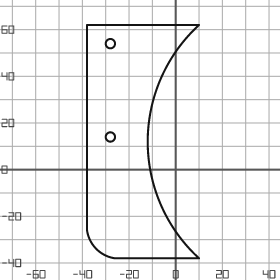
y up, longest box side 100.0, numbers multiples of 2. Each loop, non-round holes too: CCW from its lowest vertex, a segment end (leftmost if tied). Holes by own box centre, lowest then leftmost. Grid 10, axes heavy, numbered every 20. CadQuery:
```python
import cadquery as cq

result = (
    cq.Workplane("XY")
    .moveTo(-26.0, -38.0)
    .lineTo(10.0, -38.0)
    .threePointArc((-12.0, 12.0), (10.0, 62.0))
    .lineTo(-38.0, 62.0)
    .lineTo(-38.0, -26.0)
    .threePointArc((-34.0, -34.0), (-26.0, -38.0))
    .close()
    .moveTo(-28.0, 14.0)
    .circle(2.0)
    .moveTo(-28.0, 54.0)
    .circle(2.0)
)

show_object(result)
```